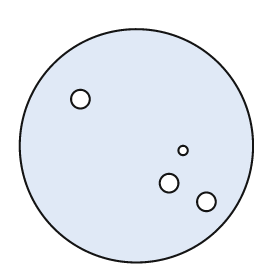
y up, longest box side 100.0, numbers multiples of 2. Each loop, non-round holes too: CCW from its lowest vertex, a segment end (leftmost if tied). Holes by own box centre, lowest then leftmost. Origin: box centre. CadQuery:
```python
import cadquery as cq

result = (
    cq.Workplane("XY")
    .moveTo(0.0, 0.0)
    .circle(50.0)
    .moveTo(30.0, -24.0)
    .circle(4.0)
    .moveTo(14.0, -16.0)
    .circle(4.0)
    .moveTo(20.0, -2.0)
    .circle(2.0)
    .moveTo(-24.0, 20.0)
    .circle(4.0)
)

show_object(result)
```